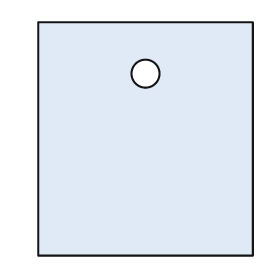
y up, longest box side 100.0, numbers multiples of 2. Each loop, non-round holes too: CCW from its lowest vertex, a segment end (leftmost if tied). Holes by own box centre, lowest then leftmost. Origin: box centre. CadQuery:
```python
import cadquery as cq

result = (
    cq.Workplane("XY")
    .moveTo(-46.0, -50.0)
    .lineTo(46.0, -50.0)
    .lineTo(46.0, 50.0)
    .lineTo(-46.0, 50.0)
    .close()
    .moveTo(0.0, 28.0)
    .circle(6.0)
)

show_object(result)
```